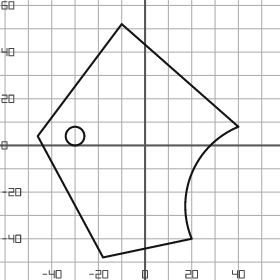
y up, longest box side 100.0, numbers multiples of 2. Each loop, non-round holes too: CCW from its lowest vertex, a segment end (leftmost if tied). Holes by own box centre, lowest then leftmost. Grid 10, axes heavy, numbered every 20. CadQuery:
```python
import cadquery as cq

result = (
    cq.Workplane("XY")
    .moveTo(-18.0, -48.0)
    .lineTo(20.0, -40.0)
    .threePointArc((20.0, -12.0), (40.0, 8.0))
    .lineTo(-10.0, 52.0)
    .lineTo(-46.0, 4.0)
    .close()
    .moveTo(-30.0, 4.0)
    .circle(4.0)
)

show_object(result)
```